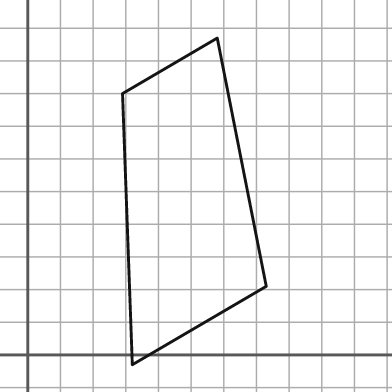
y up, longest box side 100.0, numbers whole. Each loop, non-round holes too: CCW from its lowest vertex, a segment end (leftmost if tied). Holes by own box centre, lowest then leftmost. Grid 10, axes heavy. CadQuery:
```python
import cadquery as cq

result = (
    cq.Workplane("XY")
    .moveTo(32.0, -3.0)
    .lineTo(73.0, 21.0)
    .lineTo(58.0, 97.0)
    .lineTo(29.0, 80.0)
    .close()
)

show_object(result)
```